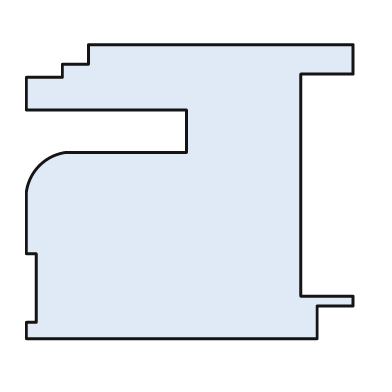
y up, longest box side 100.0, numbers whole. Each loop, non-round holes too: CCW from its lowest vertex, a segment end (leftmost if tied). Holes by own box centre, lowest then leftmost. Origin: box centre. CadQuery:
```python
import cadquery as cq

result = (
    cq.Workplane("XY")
    .moveTo(-50.0, -45.0)
    .lineTo(39.0, -45.0)
    .lineTo(39.0, -35.0)
    .lineTo(50.0, -35.0)
    .lineTo(50.0, -32.0)
    .lineTo(34.0, -32.0)
    .lineTo(34.0, 36.0)
    .lineTo(50.0, 36.0)
    .lineTo(50.0, 45.0)
    .lineTo(-31.0, 45.0)
    .lineTo(-31.0, 39.0)
    .lineTo(-39.0, 39.0)
    .lineTo(-39.0, 35.0)
    .lineTo(-50.0, 35.0)
    .lineTo(-50.0, 25.0)
    .lineTo(-1.0, 25.0)
    .lineTo(-1.0, 12.0)
    .lineTo(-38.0, 12.0)
    .threePointArc((-46.0, 8.0), (-50.0, 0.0))
    .lineTo(-50.0, -19.0)
    .lineTo(-47.0, -19.0)
    .lineTo(-47.0, -40.0)
    .lineTo(-50.0, -40.0)
    .close()
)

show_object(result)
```